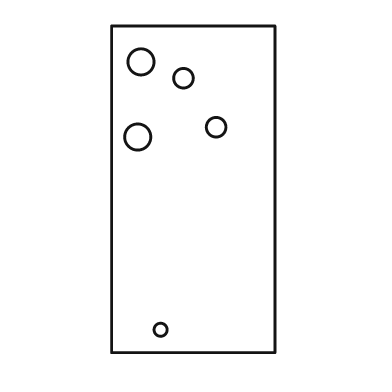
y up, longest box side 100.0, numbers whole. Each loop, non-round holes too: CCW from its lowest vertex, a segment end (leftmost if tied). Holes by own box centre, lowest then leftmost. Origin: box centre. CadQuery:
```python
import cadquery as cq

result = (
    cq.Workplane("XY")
    .moveTo(-25.0, -50.0)
    .lineTo(25.0, -50.0)
    .lineTo(25.0, 50.0)
    .lineTo(-25.0, 50.0)
    .close()
    .moveTo(-10.0, -43.0)
    .circle(2.0)
    .moveTo(-17.0, 16.0)
    .circle(4.0)
    .moveTo(7.0, 19.0)
    .circle(3.0)
    .moveTo(-3.0, 34.0)
    .circle(3.0)
    .moveTo(-16.0, 39.0)
    .circle(4.0)
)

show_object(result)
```